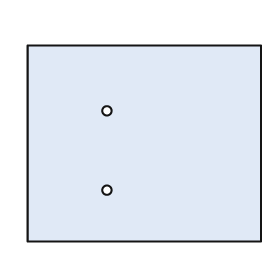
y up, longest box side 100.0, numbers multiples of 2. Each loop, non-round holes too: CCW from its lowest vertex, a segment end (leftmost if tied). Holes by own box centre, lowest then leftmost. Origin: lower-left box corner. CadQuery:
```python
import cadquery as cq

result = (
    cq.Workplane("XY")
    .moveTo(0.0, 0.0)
    .lineTo(100.0, 0.0)
    .lineTo(100.0, 84.0)
    .lineTo(0.0, 84.0)
    .close()
    .moveTo(34.0, 22.0)
    .circle(2.0)
    .moveTo(34.0, 56.0)
    .circle(2.0)
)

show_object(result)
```